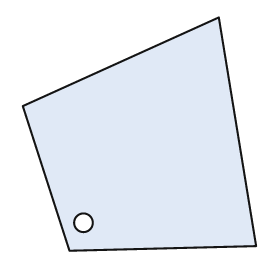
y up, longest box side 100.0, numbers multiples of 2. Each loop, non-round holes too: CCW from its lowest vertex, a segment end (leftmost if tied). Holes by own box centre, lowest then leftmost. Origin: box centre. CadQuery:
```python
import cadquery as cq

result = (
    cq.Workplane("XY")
    .moveTo(-30.0, -50.0)
    .lineTo(50.0, -48.0)
    .lineTo(34.0, 50.0)
    .lineTo(-50.0, 12.0)
    .close()
    .moveTo(-24.0, -38.0)
    .circle(4.0)
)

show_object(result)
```